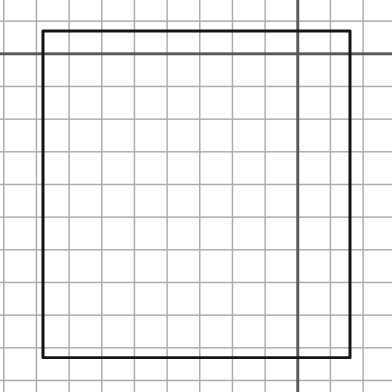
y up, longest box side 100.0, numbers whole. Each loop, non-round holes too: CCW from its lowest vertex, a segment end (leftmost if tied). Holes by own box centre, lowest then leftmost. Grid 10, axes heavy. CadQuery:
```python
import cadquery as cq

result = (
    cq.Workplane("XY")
    .moveTo(-78.0, -93.0)
    .lineTo(16.0, -93.0)
    .lineTo(16.0, 7.0)
    .lineTo(-78.0, 7.0)
    .close()
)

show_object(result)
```